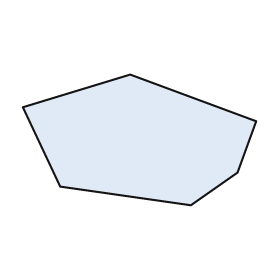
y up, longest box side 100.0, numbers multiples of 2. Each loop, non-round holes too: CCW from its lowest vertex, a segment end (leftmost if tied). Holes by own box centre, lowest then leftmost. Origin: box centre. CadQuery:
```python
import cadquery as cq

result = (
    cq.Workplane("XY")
    .moveTo(22.0, -28.0)
    .lineTo(42.0, -14.0)
    .lineTo(50.0, 8.0)
    .lineTo(-4.0, 28.0)
    .lineTo(-50.0, 14.0)
    .lineTo(-34.0, -20.0)
    .close()
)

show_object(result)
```